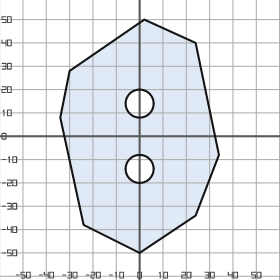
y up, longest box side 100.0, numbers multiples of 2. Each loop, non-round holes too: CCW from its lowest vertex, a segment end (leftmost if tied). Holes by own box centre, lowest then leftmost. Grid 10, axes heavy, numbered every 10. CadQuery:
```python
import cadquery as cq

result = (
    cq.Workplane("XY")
    .moveTo(0.0, -50.0)
    .lineTo(24.0, -34.0)
    .lineTo(34.0, -8.0)
    .lineTo(24.0, 40.0)
    .lineTo(2.0, 50.0)
    .lineTo(-30.0, 28.0)
    .lineTo(-34.0, 8.0)
    .lineTo(-24.0, -38.0)
    .close()
    .moveTo(0.0, -14.0)
    .circle(6.0)
    .moveTo(0.0, 14.0)
    .circle(6.0)
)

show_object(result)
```